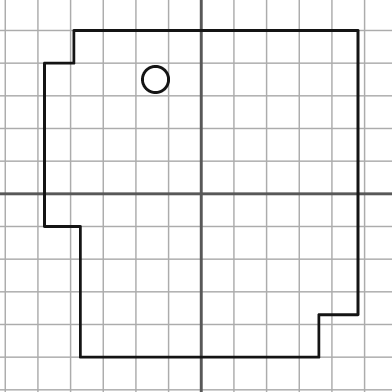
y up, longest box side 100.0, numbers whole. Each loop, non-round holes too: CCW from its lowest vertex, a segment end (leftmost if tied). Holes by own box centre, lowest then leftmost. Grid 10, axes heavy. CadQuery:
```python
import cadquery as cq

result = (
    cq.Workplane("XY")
    .moveTo(-37.0, -50.0)
    .lineTo(36.0, -50.0)
    .lineTo(36.0, -37.0)
    .lineTo(48.0, -37.0)
    .lineTo(48.0, 50.0)
    .lineTo(-39.0, 50.0)
    .lineTo(-39.0, 40.0)
    .lineTo(-48.0, 40.0)
    .lineTo(-48.0, -10.0)
    .lineTo(-37.0, -10.0)
    .close()
    .moveTo(-14.0, 35.0)
    .circle(4.0)
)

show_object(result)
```